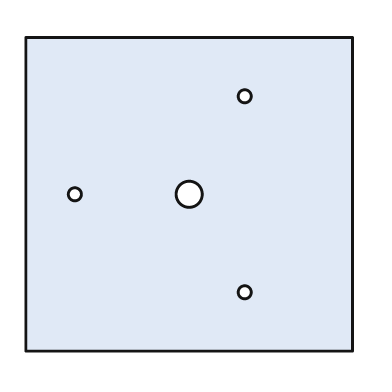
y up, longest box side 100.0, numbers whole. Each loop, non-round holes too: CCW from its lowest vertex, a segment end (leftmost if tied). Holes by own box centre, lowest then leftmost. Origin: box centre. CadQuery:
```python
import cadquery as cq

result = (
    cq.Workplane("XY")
    .moveTo(-50.0, -48.0)
    .lineTo(50.0, -48.0)
    .lineTo(50.0, 48.0)
    .lineTo(-50.0, 48.0)
    .close()
    .moveTo(17.0, -30.0)
    .circle(2.0)
    .moveTo(-35.0, 0.0)
    .circle(2.0)
    .moveTo(0.0, 0.0)
    .circle(4.0)
    .moveTo(17.0, 30.0)
    .circle(2.0)
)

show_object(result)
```